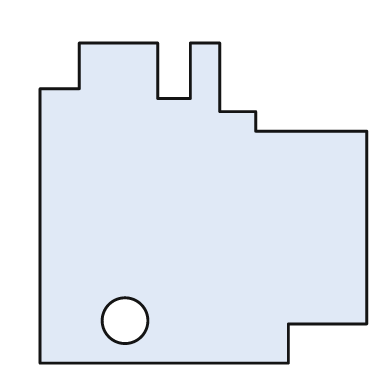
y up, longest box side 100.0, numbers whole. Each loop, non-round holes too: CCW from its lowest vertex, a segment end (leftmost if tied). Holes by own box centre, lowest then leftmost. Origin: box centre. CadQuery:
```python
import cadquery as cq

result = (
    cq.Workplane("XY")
    .moveTo(-50.0, -49.0)
    .lineTo(26.0, -49.0)
    .lineTo(26.0, -37.0)
    .lineTo(50.0, -37.0)
    .lineTo(50.0, 22.0)
    .lineTo(16.0, 22.0)
    .lineTo(16.0, 28.0)
    .lineTo(5.0, 28.0)
    .lineTo(5.0, 49.0)
    .lineTo(-4.0, 49.0)
    .lineTo(-4.0, 32.0)
    .lineTo(-14.0, 32.0)
    .lineTo(-14.0, 49.0)
    .lineTo(-38.0, 49.0)
    .lineTo(-38.0, 35.0)
    .lineTo(-50.0, 35.0)
    .close()
    .moveTo(-24.0, -36.0)
    .circle(7.0)
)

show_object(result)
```